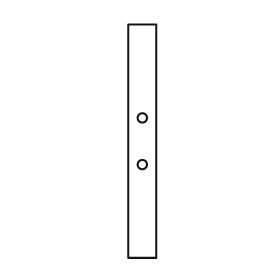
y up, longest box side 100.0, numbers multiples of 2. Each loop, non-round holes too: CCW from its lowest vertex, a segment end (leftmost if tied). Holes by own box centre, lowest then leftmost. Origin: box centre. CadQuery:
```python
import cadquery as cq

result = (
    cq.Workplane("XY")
    .moveTo(-6.0, -50.0)
    .lineTo(6.0, -50.0)
    .lineTo(6.0, 50.0)
    .lineTo(-6.0, 50.0)
    .close()
    .moveTo(0.0, -10.0)
    .circle(2.0)
    .moveTo(0.0, 10.0)
    .circle(2.0)
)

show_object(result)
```